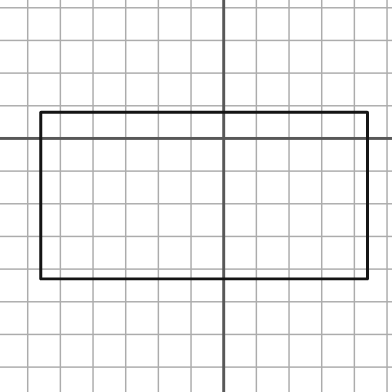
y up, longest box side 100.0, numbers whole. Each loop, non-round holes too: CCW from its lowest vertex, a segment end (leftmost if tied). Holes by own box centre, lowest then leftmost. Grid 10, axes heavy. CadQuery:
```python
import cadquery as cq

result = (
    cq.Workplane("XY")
    .moveTo(-56.0, -43.0)
    .lineTo(44.0, -43.0)
    .lineTo(44.0, 8.0)
    .lineTo(-56.0, 8.0)
    .close()
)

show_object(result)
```